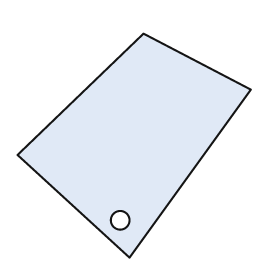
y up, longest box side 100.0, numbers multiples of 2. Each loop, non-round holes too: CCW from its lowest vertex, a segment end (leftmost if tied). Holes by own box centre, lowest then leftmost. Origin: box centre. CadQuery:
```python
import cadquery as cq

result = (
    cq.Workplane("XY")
    .moveTo(-2.0, -48.0)
    .lineTo(50.0, 24.0)
    .lineTo(4.0, 48.0)
    .lineTo(-50.0, -4.0)
    .close()
    .moveTo(-6.0, -32.0)
    .circle(4.0)
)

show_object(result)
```